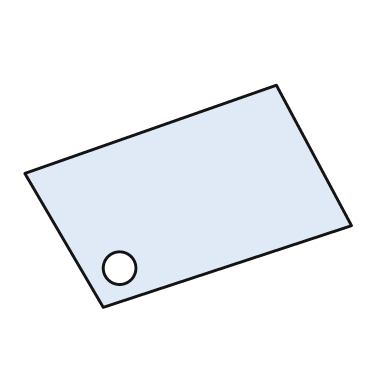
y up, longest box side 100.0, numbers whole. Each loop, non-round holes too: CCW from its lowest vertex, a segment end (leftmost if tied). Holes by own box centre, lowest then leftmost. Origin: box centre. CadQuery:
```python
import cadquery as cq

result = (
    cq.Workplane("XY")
    .moveTo(-26.0, -34.0)
    .lineTo(50.0, -9.0)
    .lineTo(27.0, 34.0)
    .lineTo(-50.0, 7.0)
    .close()
    .moveTo(-21.0, -22.0)
    .circle(5.0)
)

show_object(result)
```